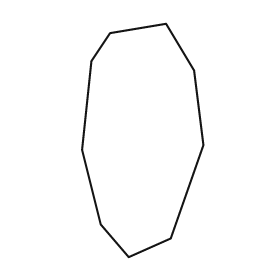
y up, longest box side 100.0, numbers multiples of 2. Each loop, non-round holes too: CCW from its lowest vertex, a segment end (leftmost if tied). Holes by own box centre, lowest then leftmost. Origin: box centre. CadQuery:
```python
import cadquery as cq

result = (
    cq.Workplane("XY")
    .moveTo(-6.0, -50.0)
    .lineTo(12.0, -42.0)
    .lineTo(26.0, -2.0)
    .lineTo(22.0, 30.0)
    .lineTo(10.0, 50.0)
    .lineTo(-14.0, 46.0)
    .lineTo(-22.0, 34.0)
    .lineTo(-26.0, -4.0)
    .lineTo(-18.0, -36.0)
    .close()
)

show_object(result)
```